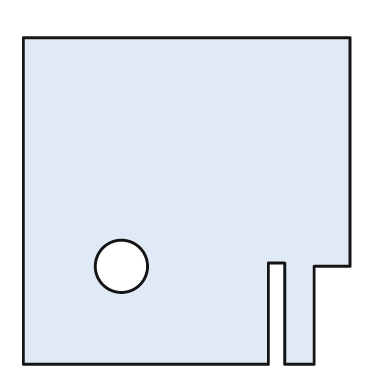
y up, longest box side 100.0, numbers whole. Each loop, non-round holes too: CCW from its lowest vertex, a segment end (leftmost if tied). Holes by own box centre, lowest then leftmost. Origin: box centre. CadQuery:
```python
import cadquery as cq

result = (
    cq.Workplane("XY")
    .moveTo(-50.0, -50.0)
    .lineTo(25.0, -50.0)
    .lineTo(25.0, -19.0)
    .lineTo(30.0, -19.0)
    .lineTo(30.0, -50.0)
    .lineTo(39.0, -50.0)
    .lineTo(39.0, -20.0)
    .lineTo(50.0, -20.0)
    .lineTo(50.0, 50.0)
    .lineTo(-50.0, 50.0)
    .close()
    .moveTo(-20.0, -20.0)
    .circle(8.0)
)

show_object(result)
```